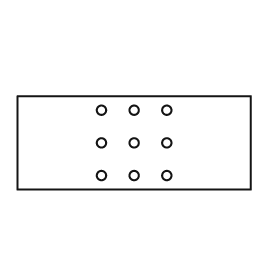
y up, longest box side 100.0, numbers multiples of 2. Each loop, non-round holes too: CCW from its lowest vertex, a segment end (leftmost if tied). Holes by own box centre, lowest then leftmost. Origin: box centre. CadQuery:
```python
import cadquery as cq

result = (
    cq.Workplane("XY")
    .moveTo(-50.0, -20.0)
    .lineTo(50.0, -20.0)
    .lineTo(50.0, 20.0)
    .lineTo(-50.0, 20.0)
    .close()
    .moveTo(-14.0, -14.0)
    .circle(2.0)
    .moveTo(0.0, -14.0)
    .circle(2.0)
    .moveTo(14.0, -14.0)
    .circle(2.0)
    .moveTo(-14.0, 0.0)
    .circle(2.0)
    .moveTo(0.0, 0.0)
    .circle(2.0)
    .moveTo(14.0, 0.0)
    .circle(2.0)
    .moveTo(-14.0, 14.0)
    .circle(2.0)
    .moveTo(0.0, 14.0)
    .circle(2.0)
    .moveTo(14.0, 14.0)
    .circle(2.0)
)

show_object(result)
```